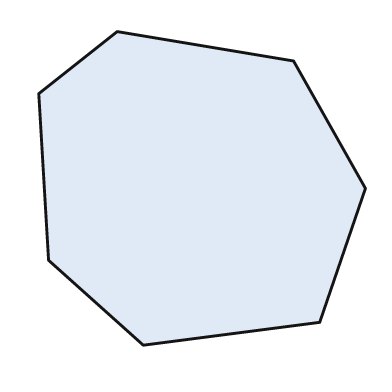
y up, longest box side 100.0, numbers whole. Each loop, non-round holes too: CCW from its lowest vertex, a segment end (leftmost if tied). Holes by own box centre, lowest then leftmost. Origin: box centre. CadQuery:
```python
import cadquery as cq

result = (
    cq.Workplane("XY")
    .moveTo(-18.0, -48.0)
    .lineTo(36.0, -41.0)
    .lineTo(50.0, 0.0)
    .lineTo(28.0, 39.0)
    .lineTo(-26.0, 48.0)
    .lineTo(-50.0, 29.0)
    .lineTo(-47.0, -22.0)
    .close()
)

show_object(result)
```